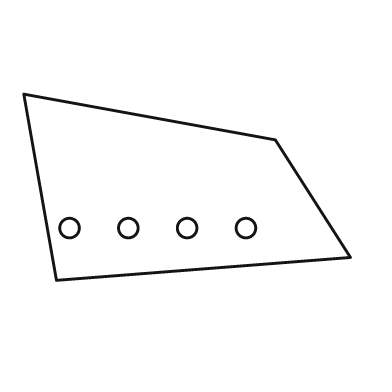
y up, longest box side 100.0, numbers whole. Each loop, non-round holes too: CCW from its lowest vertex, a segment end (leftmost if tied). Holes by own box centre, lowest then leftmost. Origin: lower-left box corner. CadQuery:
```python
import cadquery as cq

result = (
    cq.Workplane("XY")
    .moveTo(10.0, 0.0)
    .lineTo(100.0, 7.0)
    .lineTo(77.0, 43.0)
    .lineTo(0.0, 57.0)
    .close()
    .moveTo(14.0, 16.0)
    .circle(3.0)
    .moveTo(32.0, 16.0)
    .circle(3.0)
    .moveTo(50.0, 16.0)
    .circle(3.0)
    .moveTo(68.0, 16.0)
    .circle(3.0)
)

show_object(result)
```